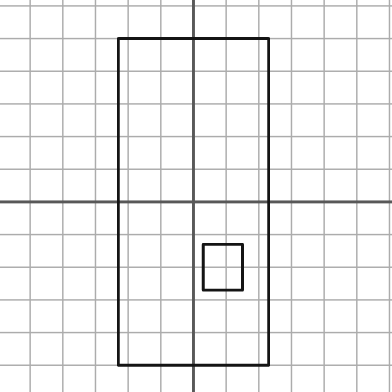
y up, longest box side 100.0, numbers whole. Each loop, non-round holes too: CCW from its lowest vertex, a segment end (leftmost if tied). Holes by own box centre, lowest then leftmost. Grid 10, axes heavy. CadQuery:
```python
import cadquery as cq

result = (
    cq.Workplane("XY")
    .moveTo(-23.0, -50.0)
    .lineTo(23.0, -50.0)
    .lineTo(23.0, 50.0)
    .lineTo(-23.0, 50.0)
    .close()
    .moveTo(3.0, -27.0)
    .lineTo(15.0, -27.0)
    .lineTo(15.0, -13.0)
    .lineTo(3.0, -13.0)
    .close()
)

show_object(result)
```